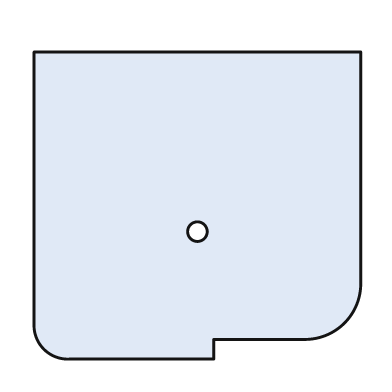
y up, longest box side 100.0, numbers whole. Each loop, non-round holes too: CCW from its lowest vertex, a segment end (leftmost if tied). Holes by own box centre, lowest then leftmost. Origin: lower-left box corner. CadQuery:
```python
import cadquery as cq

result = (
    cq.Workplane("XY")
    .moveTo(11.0, 0.0)
    .lineTo(55.0, 0.0)
    .lineTo(55.0, 6.0)
    .lineTo(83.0, 6.0)
    .threePointArc((95.0, 11.0), (100.0, 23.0))
    .lineTo(100.0, 94.0)
    .lineTo(0.0, 94.0)
    .lineTo(0.0, 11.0)
    .threePointArc((3.0, 3.0), (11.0, 0.0))
    .close()
    .moveTo(50.0, 39.0)
    .circle(3.0)
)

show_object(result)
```